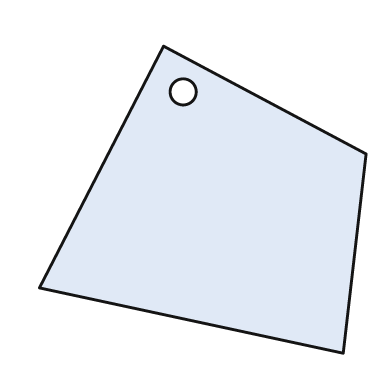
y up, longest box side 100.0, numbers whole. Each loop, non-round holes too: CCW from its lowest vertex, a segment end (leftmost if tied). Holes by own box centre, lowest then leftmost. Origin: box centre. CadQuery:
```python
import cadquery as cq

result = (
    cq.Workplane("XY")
    .moveTo(43.0, -47.0)
    .lineTo(50.0, 14.0)
    .lineTo(-12.0, 47.0)
    .lineTo(-50.0, -27.0)
    .close()
    .moveTo(-6.0, 33.0)
    .circle(4.0)
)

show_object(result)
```